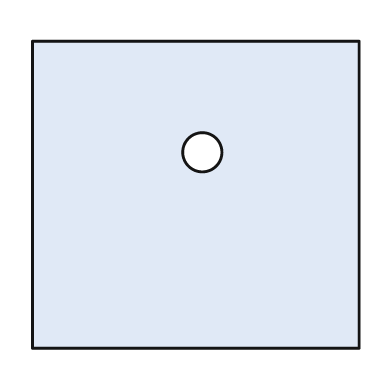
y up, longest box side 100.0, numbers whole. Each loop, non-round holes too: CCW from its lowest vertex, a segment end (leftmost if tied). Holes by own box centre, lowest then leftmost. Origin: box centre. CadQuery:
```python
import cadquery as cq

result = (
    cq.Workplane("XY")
    .moveTo(-50.0, -47.0)
    .lineTo(50.0, -47.0)
    .lineTo(50.0, 47.0)
    .lineTo(-50.0, 47.0)
    .close()
    .moveTo(2.0, 13.0)
    .circle(6.0)
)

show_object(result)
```